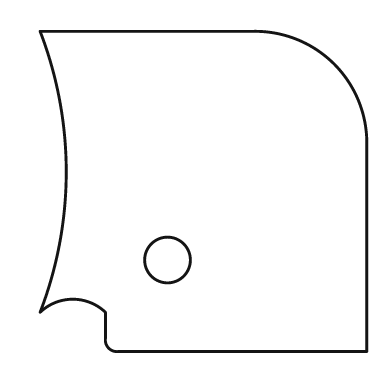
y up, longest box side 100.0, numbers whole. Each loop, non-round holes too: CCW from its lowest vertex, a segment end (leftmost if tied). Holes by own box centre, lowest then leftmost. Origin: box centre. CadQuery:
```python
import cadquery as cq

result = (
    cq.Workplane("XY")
    .moveTo(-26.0, -49.0)
    .lineTo(50.0, -49.0)
    .lineTo(50.0, 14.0)
    .threePointArc((40.0, 39.0), (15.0, 49.0))
    .lineTo(-50.0, 49.0)
    .threePointArc((-42.0, 6.0), (-50.0, -37.0))
    .threePointArc((-40.0, -33.0), (-30.0, -37.0))
    .lineTo(-30.0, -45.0)
    .threePointArc((-29.0, -48.0), (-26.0, -49.0))
    .close()
    .moveTo(-11.0, -21.0)
    .circle(7.0)
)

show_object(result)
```